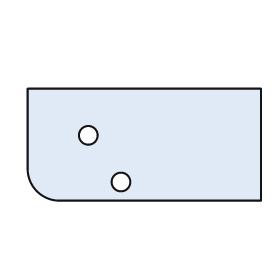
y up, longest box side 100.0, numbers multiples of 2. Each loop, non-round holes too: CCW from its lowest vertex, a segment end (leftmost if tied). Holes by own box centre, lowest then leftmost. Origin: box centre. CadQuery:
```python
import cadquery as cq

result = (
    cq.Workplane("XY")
    .moveTo(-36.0, -24.0)
    .lineTo(50.0, -24.0)
    .lineTo(50.0, 24.0)
    .lineTo(-50.0, 24.0)
    .lineTo(-50.0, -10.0)
    .threePointArc((-46.0, -20.0), (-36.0, -24.0))
    .close()
    .moveTo(-10.0, -16.0)
    .circle(4.0)
    .moveTo(-24.0, 4.0)
    .circle(4.0)
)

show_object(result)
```